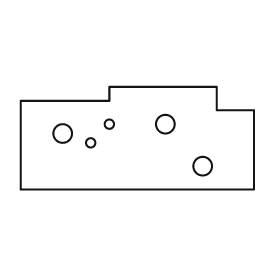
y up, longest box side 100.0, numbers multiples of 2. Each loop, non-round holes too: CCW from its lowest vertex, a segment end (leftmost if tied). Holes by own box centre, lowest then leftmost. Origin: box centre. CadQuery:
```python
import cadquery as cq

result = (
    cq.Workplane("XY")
    .moveTo(-50.0, -22.0)
    .lineTo(50.0, -22.0)
    .lineTo(50.0, 12.0)
    .lineTo(34.0, 12.0)
    .lineTo(34.0, 22.0)
    .lineTo(-12.0, 22.0)
    .lineTo(-12.0, 16.0)
    .lineTo(-50.0, 16.0)
    .close()
    .moveTo(28.0, -12.0)
    .circle(4.0)
    .moveTo(-20.0, -2.0)
    .circle(2.0)
    .moveTo(-32.0, 2.0)
    .circle(4.0)
    .moveTo(-12.0, 6.0)
    .circle(2.0)
    .moveTo(12.0, 6.0)
    .circle(4.0)
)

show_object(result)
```